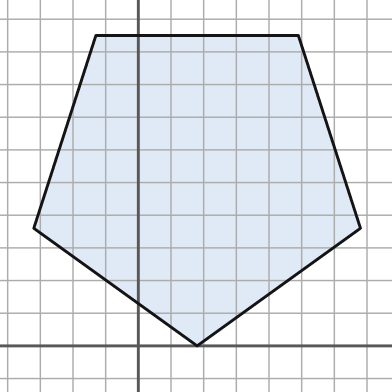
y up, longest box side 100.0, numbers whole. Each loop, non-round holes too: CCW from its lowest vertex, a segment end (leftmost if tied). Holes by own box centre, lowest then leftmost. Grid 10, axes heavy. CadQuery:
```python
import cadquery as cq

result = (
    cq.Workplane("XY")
    .moveTo(18.0, 0.0)
    .lineTo(68.0, 36.0)
    .lineTo(49.0, 95.0)
    .lineTo(-13.0, 95.0)
    .lineTo(-32.0, 36.0)
    .close()
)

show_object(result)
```